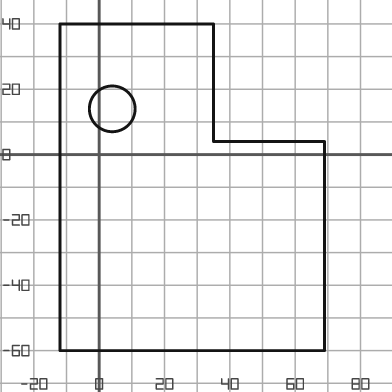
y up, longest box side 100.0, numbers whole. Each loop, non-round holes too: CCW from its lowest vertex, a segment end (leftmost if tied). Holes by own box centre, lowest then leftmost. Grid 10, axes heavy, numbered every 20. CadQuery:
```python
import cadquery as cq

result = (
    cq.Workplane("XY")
    .moveTo(-12.0, -60.0)
    .lineTo(69.0, -60.0)
    .lineTo(69.0, 4.0)
    .lineTo(35.0, 4.0)
    .lineTo(35.0, 40.0)
    .lineTo(-12.0, 40.0)
    .close()
    .moveTo(4.0, 14.0)
    .circle(7.0)
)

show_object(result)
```